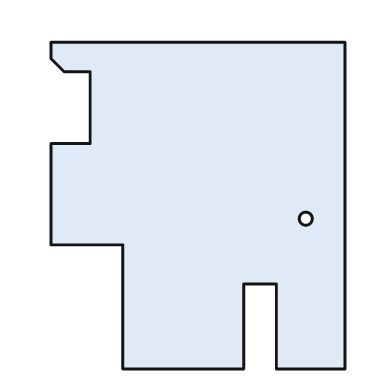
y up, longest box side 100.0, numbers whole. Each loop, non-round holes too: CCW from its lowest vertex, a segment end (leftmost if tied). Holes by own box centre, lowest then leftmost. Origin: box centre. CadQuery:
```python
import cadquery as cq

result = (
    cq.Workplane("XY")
    .moveTo(-23.0, -50.0)
    .lineTo(14.0, -50.0)
    .lineTo(14.0, -24.0)
    .lineTo(24.0, -24.0)
    .lineTo(24.0, -50.0)
    .lineTo(45.0, -50.0)
    .lineTo(45.0, 50.0)
    .lineTo(-45.0, 50.0)
    .lineTo(-45.0, 45.0)
    .lineTo(-41.0, 41.0)
    .lineTo(-33.0, 41.0)
    .lineTo(-33.0, 19.0)
    .lineTo(-45.0, 19.0)
    .lineTo(-45.0, -12.0)
    .lineTo(-23.0, -12.0)
    .close()
    .moveTo(33.0, -4.0)
    .circle(2.0)
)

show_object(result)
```